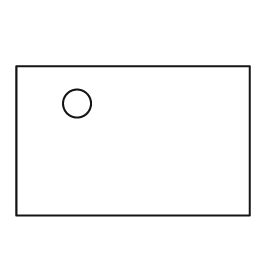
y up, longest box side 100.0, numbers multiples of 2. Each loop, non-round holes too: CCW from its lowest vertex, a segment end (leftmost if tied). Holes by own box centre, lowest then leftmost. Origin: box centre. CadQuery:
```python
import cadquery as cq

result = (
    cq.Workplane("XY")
    .moveTo(-50.0, -32.0)
    .lineTo(50.0, -32.0)
    .lineTo(50.0, 32.0)
    .lineTo(-50.0, 32.0)
    .close()
    .moveTo(-24.0, 16.0)
    .circle(6.0)
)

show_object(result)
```